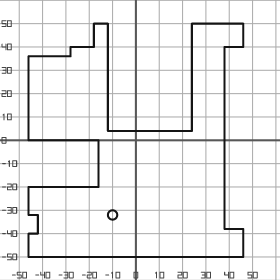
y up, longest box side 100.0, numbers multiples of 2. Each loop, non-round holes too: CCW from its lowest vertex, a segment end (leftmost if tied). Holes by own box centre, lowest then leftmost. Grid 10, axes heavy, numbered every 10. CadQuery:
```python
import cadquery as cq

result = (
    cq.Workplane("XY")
    .moveTo(-46.0, -50.0)
    .lineTo(46.0, -50.0)
    .lineTo(46.0, -38.0)
    .lineTo(38.0, -38.0)
    .lineTo(38.0, 40.0)
    .lineTo(46.0, 40.0)
    .lineTo(46.0, 50.0)
    .lineTo(24.0, 50.0)
    .lineTo(24.0, 4.0)
    .lineTo(-12.0, 4.0)
    .lineTo(-12.0, 50.0)
    .lineTo(-18.0, 50.0)
    .lineTo(-18.0, 40.0)
    .lineTo(-28.0, 40.0)
    .lineTo(-28.0, 36.0)
    .lineTo(-46.0, 36.0)
    .lineTo(-46.0, 0.0)
    .lineTo(-16.0, 0.0)
    .lineTo(-16.0, -20.0)
    .lineTo(-46.0, -20.0)
    .lineTo(-46.0, -32.0)
    .lineTo(-42.0, -32.0)
    .lineTo(-42.0, -40.0)
    .lineTo(-46.0, -40.0)
    .close()
    .moveTo(-10.0, -32.0)
    .circle(2.0)
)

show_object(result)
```